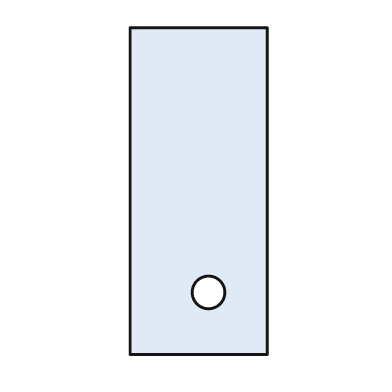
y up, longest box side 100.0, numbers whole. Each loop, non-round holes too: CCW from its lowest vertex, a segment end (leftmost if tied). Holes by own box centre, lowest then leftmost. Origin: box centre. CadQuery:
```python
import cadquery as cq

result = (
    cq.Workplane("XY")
    .moveTo(-21.0, -50.0)
    .lineTo(21.0, -50.0)
    .lineTo(21.0, 50.0)
    .lineTo(-21.0, 50.0)
    .close()
    .moveTo(3.0, -31.0)
    .circle(5.0)
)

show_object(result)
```